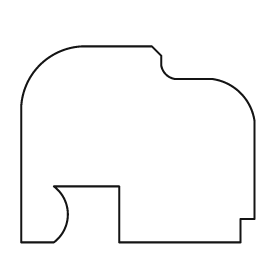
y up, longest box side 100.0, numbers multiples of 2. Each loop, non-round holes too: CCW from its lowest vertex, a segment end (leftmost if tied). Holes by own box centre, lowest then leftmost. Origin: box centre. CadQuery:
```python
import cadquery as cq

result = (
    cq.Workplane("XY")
    .moveTo(-50.0, -42.0)
    .lineTo(-36.0, -42.0)
    .threePointArc((-30.0, -30.0), (-36.0, -18.0))
    .lineTo(-8.0, -18.0)
    .lineTo(-8.0, -42.0)
    .lineTo(44.0, -42.0)
    .lineTo(44.0, -32.0)
    .lineTo(50.0, -32.0)
    .lineTo(50.0, 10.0)
    .threePointArc((44.0, 22.0), (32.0, 28.0))
    .lineTo(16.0, 28.0)
    .threePointArc((12.0, 30.0), (10.0, 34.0))
    .lineTo(10.0, 38.0)
    .lineTo(6.0, 42.0)
    .lineTo(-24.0, 42.0)
    .threePointArc((-42.0, 34.0), (-50.0, 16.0))
    .close()
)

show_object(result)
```